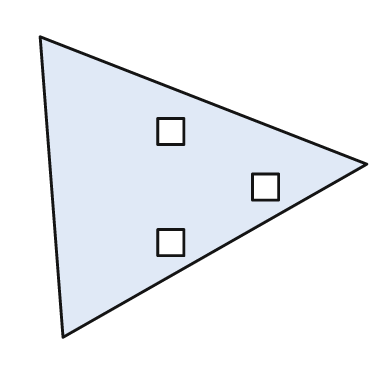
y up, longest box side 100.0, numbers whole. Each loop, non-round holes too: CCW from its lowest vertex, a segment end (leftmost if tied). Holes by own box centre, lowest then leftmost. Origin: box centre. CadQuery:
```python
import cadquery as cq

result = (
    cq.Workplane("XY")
    .moveTo(-43.0, -46.0)
    .lineTo(50.0, 7.0)
    .lineTo(-50.0, 46.0)
    .close()
    .moveTo(-14.0, -21.0)
    .lineTo(-6.0, -21.0)
    .lineTo(-6.0, -13.0)
    .lineTo(-14.0, -13.0)
    .close()
    .moveTo(15.0, -4.0)
    .lineTo(23.0, -4.0)
    .lineTo(23.0, 4.0)
    .lineTo(15.0, 4.0)
    .close()
    .moveTo(-14.0, 13.0)
    .lineTo(-6.0, 13.0)
    .lineTo(-6.0, 21.0)
    .lineTo(-14.0, 21.0)
    .close()
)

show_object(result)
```